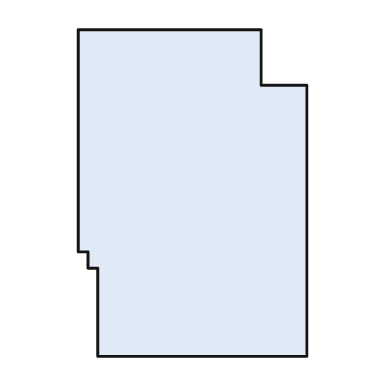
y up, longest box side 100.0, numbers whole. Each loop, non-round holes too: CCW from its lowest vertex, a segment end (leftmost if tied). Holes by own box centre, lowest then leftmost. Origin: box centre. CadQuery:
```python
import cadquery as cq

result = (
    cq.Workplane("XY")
    .moveTo(-29.0, -50.0)
    .lineTo(35.0, -50.0)
    .lineTo(35.0, 33.0)
    .lineTo(21.0, 33.0)
    .lineTo(21.0, 50.0)
    .lineTo(-35.0, 50.0)
    .lineTo(-35.0, -18.0)
    .lineTo(-32.0, -18.0)
    .lineTo(-32.0, -23.0)
    .lineTo(-29.0, -23.0)
    .close()
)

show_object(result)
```